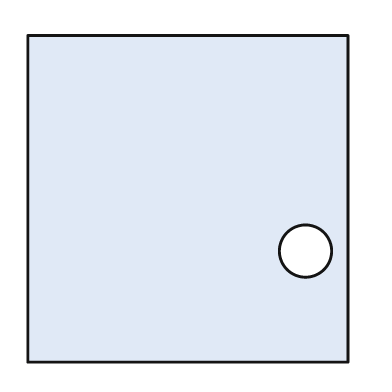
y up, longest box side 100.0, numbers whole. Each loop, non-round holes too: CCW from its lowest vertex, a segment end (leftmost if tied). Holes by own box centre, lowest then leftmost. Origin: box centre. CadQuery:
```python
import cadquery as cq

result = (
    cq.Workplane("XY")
    .moveTo(-49.0, -50.0)
    .lineTo(49.0, -50.0)
    .lineTo(49.0, 50.0)
    .lineTo(-49.0, 50.0)
    .close()
    .moveTo(36.0, -16.0)
    .circle(8.0)
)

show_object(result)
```